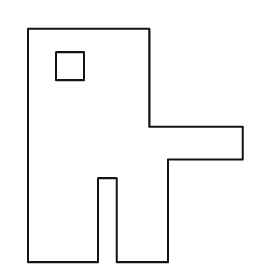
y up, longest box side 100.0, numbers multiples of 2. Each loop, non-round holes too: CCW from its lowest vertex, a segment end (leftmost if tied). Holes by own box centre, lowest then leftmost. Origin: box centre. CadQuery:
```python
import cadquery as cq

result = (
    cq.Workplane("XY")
    .moveTo(-46.0, -50.0)
    .lineTo(-16.0, -50.0)
    .lineTo(-16.0, -14.0)
    .lineTo(-8.0, -14.0)
    .lineTo(-8.0, -50.0)
    .lineTo(14.0, -50.0)
    .lineTo(14.0, -6.0)
    .lineTo(46.0, -6.0)
    .lineTo(46.0, 8.0)
    .lineTo(6.0, 8.0)
    .lineTo(6.0, 50.0)
    .lineTo(-46.0, 50.0)
    .close()
    .moveTo(-34.0, 28.0)
    .lineTo(-22.0, 28.0)
    .lineTo(-22.0, 40.0)
    .lineTo(-34.0, 40.0)
    .close()
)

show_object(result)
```